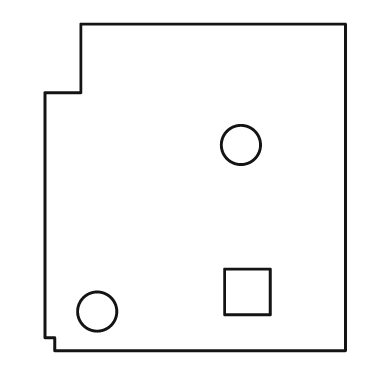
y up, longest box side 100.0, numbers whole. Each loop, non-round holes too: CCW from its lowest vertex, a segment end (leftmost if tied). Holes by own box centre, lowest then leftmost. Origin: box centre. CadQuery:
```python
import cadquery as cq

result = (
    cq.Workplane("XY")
    .moveTo(-43.0, -50.0)
    .lineTo(46.0, -50.0)
    .lineTo(46.0, 50.0)
    .lineTo(-35.0, 50.0)
    .lineTo(-35.0, 29.0)
    .lineTo(-46.0, 29.0)
    .lineTo(-46.0, -46.0)
    .lineTo(-43.0, -46.0)
    .close()
    .moveTo(-30.0, -38.0)
    .circle(6.0)
    .moveTo(9.0, -39.0)
    .lineTo(23.0, -39.0)
    .lineTo(23.0, -25.0)
    .lineTo(9.0, -25.0)
    .close()
    .moveTo(14.0, 13.0)
    .circle(6.0)
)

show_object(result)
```